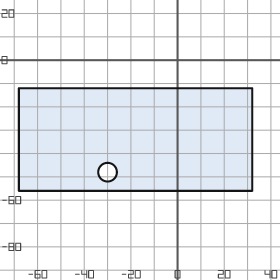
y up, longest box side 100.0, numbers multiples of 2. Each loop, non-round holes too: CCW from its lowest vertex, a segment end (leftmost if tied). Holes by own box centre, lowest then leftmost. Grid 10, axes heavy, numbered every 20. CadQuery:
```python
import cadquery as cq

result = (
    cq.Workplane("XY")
    .moveTo(-68.0, -56.0)
    .lineTo(32.0, -56.0)
    .lineTo(32.0, -12.0)
    .lineTo(-68.0, -12.0)
    .close()
    .moveTo(-30.0, -48.0)
    .circle(4.0)
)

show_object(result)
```